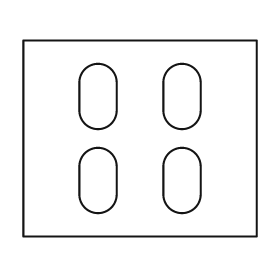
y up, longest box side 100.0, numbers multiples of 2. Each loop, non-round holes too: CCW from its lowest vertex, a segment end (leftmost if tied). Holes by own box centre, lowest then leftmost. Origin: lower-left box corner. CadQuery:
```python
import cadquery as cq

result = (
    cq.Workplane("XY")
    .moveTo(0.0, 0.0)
    .lineTo(100.0, 0.0)
    .lineTo(100.0, 84.0)
    .lineTo(0.0, 84.0)
    .close()
    .moveTo(24.0, 18.0)
    .threePointArc((32.0, 10.0), (40.0, 18.0))
    .lineTo(40.0, 30.0)
    .threePointArc((32.0, 38.0), (24.0, 30.0))
    .close()
    .moveTo(60.0, 18.0)
    .threePointArc((68.0, 10.0), (76.0, 18.0))
    .lineTo(76.0, 30.0)
    .threePointArc((68.0, 38.0), (60.0, 30.0))
    .close()
    .moveTo(24.0, 54.0)
    .threePointArc((32.0, 46.0), (40.0, 54.0))
    .lineTo(40.0, 66.0)
    .threePointArc((32.0, 74.0), (24.0, 66.0))
    .close()
    .moveTo(60.0, 54.0)
    .threePointArc((68.0, 46.0), (76.0, 54.0))
    .lineTo(76.0, 66.0)
    .threePointArc((68.0, 74.0), (60.0, 66.0))
    .close()
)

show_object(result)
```